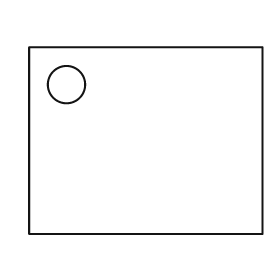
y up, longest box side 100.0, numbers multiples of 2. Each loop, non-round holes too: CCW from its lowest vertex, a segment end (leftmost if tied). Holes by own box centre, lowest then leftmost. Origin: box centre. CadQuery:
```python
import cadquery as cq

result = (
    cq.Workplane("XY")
    .moveTo(-50.0, -40.0)
    .lineTo(50.0, -40.0)
    .lineTo(50.0, 40.0)
    .lineTo(-50.0, 40.0)
    .close()
    .moveTo(-34.0, 24.0)
    .circle(8.0)
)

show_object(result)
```